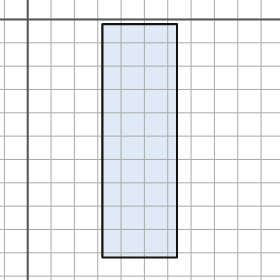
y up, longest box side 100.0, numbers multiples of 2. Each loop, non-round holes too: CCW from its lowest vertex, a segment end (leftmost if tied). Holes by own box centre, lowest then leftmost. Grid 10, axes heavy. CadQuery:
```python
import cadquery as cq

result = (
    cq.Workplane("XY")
    .moveTo(32.0, -102.0)
    .lineTo(64.0, -102.0)
    .lineTo(64.0, -2.0)
    .lineTo(32.0, -2.0)
    .close()
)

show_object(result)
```